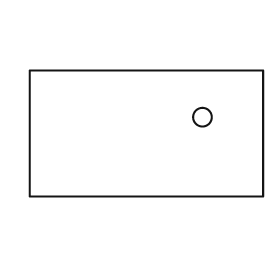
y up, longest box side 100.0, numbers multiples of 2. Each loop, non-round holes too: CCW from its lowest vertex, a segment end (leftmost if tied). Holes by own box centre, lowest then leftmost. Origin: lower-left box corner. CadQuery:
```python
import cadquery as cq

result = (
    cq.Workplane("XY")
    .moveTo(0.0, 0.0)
    .lineTo(100.0, 0.0)
    .lineTo(100.0, 54.0)
    .lineTo(0.0, 54.0)
    .close()
    .moveTo(74.0, 34.0)
    .circle(4.0)
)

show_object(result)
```